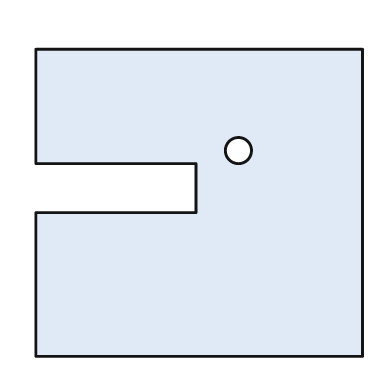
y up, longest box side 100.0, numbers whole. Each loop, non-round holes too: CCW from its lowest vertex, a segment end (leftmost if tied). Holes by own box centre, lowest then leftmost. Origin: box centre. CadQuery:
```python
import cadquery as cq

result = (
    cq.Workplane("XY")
    .moveTo(-50.0, -47.0)
    .lineTo(50.0, -47.0)
    .lineTo(50.0, 47.0)
    .lineTo(-50.0, 47.0)
    .lineTo(-50.0, 12.0)
    .lineTo(-1.0, 12.0)
    .lineTo(-1.0, -3.0)
    .lineTo(-50.0, -3.0)
    .close()
    .moveTo(12.0, 16.0)
    .circle(4.0)
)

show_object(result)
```